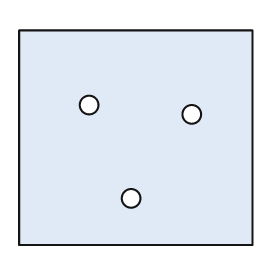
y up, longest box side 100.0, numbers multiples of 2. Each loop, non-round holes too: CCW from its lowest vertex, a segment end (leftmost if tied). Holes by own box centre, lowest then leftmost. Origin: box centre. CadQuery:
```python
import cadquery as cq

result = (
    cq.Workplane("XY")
    .moveTo(-50.0, -46.0)
    .lineTo(50.0, -46.0)
    .lineTo(50.0, 46.0)
    .lineTo(-50.0, 46.0)
    .close()
    .moveTo(-2.0, -26.0)
    .circle(4.0)
    .moveTo(24.0, 10.0)
    .circle(4.0)
    .moveTo(-20.0, 14.0)
    .circle(4.0)
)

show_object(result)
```